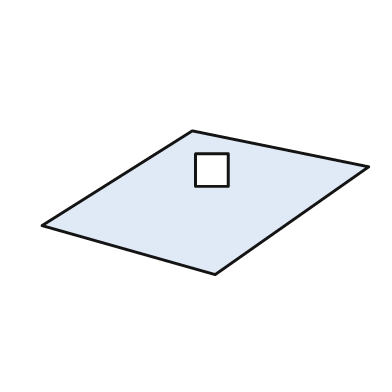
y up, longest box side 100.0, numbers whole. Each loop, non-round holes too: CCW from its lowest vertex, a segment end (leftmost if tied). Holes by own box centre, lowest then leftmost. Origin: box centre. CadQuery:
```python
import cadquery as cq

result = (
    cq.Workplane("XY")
    .moveTo(3.0, -22.0)
    .lineTo(50.0, 11.0)
    .lineTo(-4.0, 22.0)
    .lineTo(-50.0, -7.0)
    .close()
    .moveTo(-3.0, 5.0)
    .lineTo(7.0, 5.0)
    .lineTo(7.0, 15.0)
    .lineTo(-3.0, 15.0)
    .close()
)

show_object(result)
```